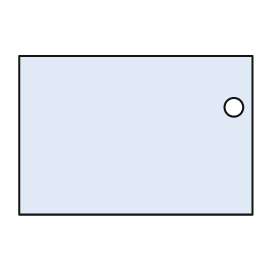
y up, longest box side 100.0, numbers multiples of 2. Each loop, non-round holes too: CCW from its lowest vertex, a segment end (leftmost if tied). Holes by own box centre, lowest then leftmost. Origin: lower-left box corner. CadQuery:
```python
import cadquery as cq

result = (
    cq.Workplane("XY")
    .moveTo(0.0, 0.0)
    .lineTo(100.0, 0.0)
    .lineTo(100.0, 68.0)
    .lineTo(0.0, 68.0)
    .close()
    .moveTo(92.0, 46.0)
    .circle(4.0)
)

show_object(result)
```